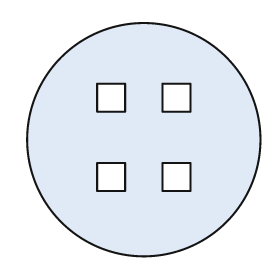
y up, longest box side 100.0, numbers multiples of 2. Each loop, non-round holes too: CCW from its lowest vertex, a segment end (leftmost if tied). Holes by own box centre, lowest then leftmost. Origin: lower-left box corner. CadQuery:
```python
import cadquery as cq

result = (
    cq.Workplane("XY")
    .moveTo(50.0, 50.0)
    .circle(50.0)
    .moveTo(30.0, 28.0)
    .lineTo(42.0, 28.0)
    .lineTo(42.0, 40.0)
    .lineTo(30.0, 40.0)
    .close()
    .moveTo(58.0, 28.0)
    .lineTo(70.0, 28.0)
    .lineTo(70.0, 40.0)
    .lineTo(58.0, 40.0)
    .close()
    .moveTo(30.0, 62.0)
    .lineTo(42.0, 62.0)
    .lineTo(42.0, 74.0)
    .lineTo(30.0, 74.0)
    .close()
    .moveTo(58.0, 62.0)
    .lineTo(70.0, 62.0)
    .lineTo(70.0, 74.0)
    .lineTo(58.0, 74.0)
    .close()
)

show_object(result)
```